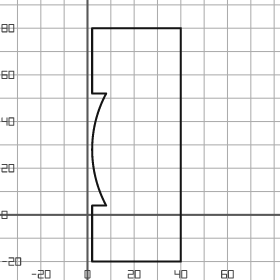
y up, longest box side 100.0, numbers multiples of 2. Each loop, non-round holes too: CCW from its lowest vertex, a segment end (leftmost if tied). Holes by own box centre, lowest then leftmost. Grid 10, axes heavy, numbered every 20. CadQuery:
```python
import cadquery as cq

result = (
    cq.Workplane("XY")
    .moveTo(2.0, -20.0)
    .lineTo(40.0, -20.0)
    .lineTo(40.0, 80.0)
    .lineTo(2.0, 80.0)
    .lineTo(2.0, 52.0)
    .lineTo(8.0, 52.0)
    .threePointArc((2.0, 28.0), (8.0, 4.0))
    .lineTo(2.0, 4.0)
    .close()
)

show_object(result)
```